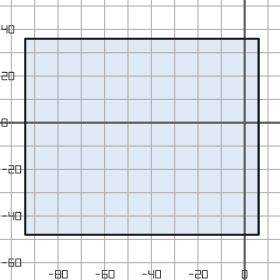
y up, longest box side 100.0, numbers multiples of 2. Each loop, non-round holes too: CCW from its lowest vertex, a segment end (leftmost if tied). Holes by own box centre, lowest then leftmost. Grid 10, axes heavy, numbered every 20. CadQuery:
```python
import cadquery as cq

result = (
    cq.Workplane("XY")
    .moveTo(-94.0, -48.0)
    .lineTo(6.0, -48.0)
    .lineTo(6.0, 36.0)
    .lineTo(-94.0, 36.0)
    .close()
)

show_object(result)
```